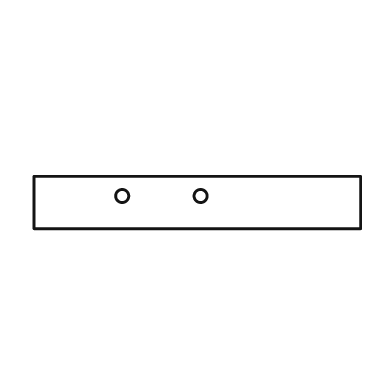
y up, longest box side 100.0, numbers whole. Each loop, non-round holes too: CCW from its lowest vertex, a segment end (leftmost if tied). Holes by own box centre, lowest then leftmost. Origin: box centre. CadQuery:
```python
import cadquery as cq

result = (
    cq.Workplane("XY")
    .moveTo(-50.0, -8.0)
    .lineTo(50.0, -8.0)
    .lineTo(50.0, 8.0)
    .lineTo(-50.0, 8.0)
    .close()
    .moveTo(-23.0, 2.0)
    .circle(2.0)
    .moveTo(1.0, 2.0)
    .circle(2.0)
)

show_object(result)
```